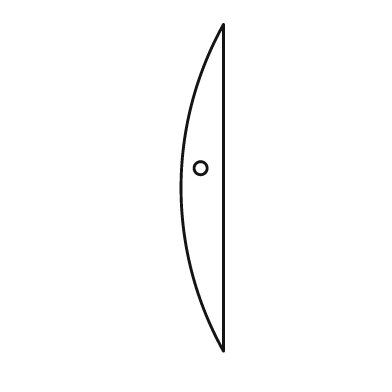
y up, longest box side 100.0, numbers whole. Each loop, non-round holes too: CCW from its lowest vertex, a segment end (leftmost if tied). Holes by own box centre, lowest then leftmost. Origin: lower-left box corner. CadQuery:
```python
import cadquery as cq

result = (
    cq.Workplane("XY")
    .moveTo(13.0, 0.0)
    .lineTo(13.0, 100.0)
    .threePointArc((0.0, 50.0), (13.0, 0.0))
    .close()
    .moveTo(6.0, 56.0)
    .circle(2.0)
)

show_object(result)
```